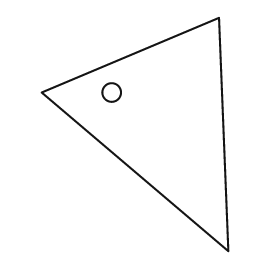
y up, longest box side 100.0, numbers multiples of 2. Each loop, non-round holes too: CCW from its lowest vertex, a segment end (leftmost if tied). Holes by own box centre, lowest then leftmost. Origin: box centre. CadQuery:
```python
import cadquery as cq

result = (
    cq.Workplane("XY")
    .moveTo(40.0, -50.0)
    .lineTo(36.0, 50.0)
    .lineTo(-40.0, 18.0)
    .close()
    .moveTo(-10.0, 18.0)
    .circle(4.0)
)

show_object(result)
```